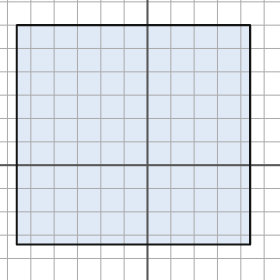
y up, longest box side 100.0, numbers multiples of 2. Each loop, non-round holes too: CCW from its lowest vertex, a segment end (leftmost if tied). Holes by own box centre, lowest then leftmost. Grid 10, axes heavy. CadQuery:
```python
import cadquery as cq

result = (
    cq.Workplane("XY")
    .moveTo(-56.0, -34.0)
    .lineTo(44.0, -34.0)
    .lineTo(44.0, 60.0)
    .lineTo(-56.0, 60.0)
    .close()
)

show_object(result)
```